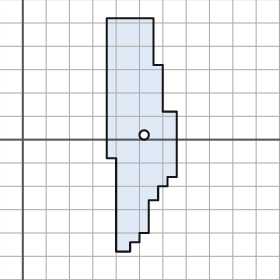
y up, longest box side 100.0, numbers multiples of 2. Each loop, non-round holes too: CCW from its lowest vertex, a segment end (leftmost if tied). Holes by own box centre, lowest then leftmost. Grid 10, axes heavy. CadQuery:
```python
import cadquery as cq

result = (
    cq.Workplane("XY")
    .moveTo(40.0, -48.0)
    .lineTo(46.0, -48.0)
    .lineTo(46.0, -44.0)
    .lineTo(50.0, -44.0)
    .lineTo(50.0, -40.0)
    .lineTo(54.0, -40.0)
    .lineTo(54.0, -26.0)
    .lineTo(58.0, -26.0)
    .lineTo(58.0, -20.0)
    .lineTo(62.0, -20.0)
    .lineTo(62.0, -16.0)
    .lineTo(66.0, -16.0)
    .lineTo(66.0, 12.0)
    .lineTo(60.0, 12.0)
    .lineTo(60.0, 32.0)
    .lineTo(56.0, 32.0)
    .lineTo(56.0, 52.0)
    .lineTo(36.0, 52.0)
    .lineTo(36.0, -8.0)
    .lineTo(40.0, -8.0)
    .close()
    .moveTo(52.0, 2.0)
    .circle(2.0)
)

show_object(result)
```